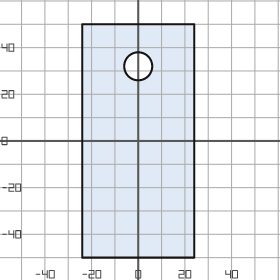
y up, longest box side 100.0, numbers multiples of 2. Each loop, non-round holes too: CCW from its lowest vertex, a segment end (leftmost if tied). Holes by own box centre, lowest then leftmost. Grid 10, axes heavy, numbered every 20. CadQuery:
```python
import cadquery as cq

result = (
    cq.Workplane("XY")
    .moveTo(-24.0, -50.0)
    .lineTo(24.0, -50.0)
    .lineTo(24.0, 50.0)
    .lineTo(-24.0, 50.0)
    .close()
    .moveTo(0.0, 32.0)
    .circle(6.0)
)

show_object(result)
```